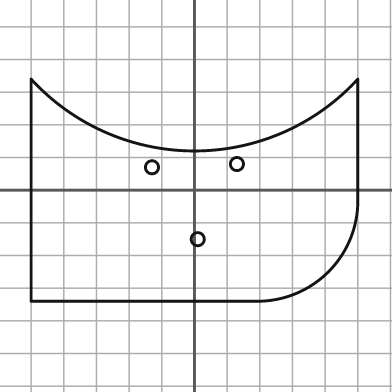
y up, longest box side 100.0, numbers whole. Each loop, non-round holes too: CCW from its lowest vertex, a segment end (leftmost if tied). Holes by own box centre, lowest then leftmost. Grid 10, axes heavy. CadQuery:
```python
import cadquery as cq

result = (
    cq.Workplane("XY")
    .moveTo(-50.0, -34.0)
    .lineTo(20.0, -34.0)
    .threePointArc((41.0, -25.0), (50.0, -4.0))
    .lineTo(50.0, 34.0)
    .threePointArc((0.0, 12.0), (-50.0, 34.0))
    .close()
    .moveTo(1.0, -15.0)
    .circle(2.0)
    .moveTo(-13.0, 7.0)
    .circle(2.0)
    .moveTo(13.0, 8.0)
    .circle(2.0)
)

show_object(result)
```